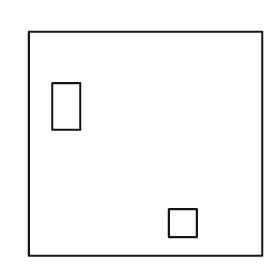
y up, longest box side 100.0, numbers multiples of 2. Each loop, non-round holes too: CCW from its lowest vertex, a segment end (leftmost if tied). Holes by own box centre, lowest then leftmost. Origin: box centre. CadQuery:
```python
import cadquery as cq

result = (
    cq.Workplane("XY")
    .moveTo(-50.0, -48.0)
    .lineTo(50.0, -48.0)
    .lineTo(50.0, 48.0)
    .lineTo(-50.0, 48.0)
    .close()
    .moveTo(10.0, -40.0)
    .lineTo(22.0, -40.0)
    .lineTo(22.0, -28.0)
    .lineTo(10.0, -28.0)
    .close()
    .moveTo(-40.0, 6.0)
    .lineTo(-28.0, 6.0)
    .lineTo(-28.0, 26.0)
    .lineTo(-40.0, 26.0)
    .close()
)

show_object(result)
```